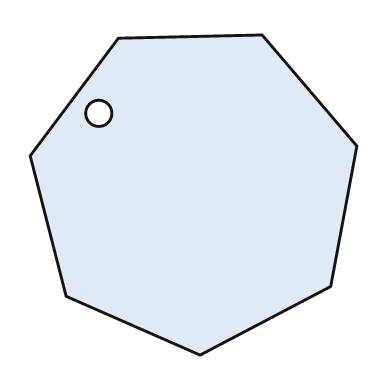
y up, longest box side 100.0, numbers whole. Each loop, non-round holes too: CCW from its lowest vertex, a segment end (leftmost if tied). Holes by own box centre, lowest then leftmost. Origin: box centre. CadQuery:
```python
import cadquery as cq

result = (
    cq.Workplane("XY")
    .moveTo(2.0, -49.0)
    .lineTo(42.0, -28.0)
    .lineTo(50.0, 15.0)
    .lineTo(21.0, 49.0)
    .lineTo(-23.0, 48.0)
    .lineTo(-50.0, 12.0)
    .lineTo(-39.0, -31.0)
    .close()
    .moveTo(-29.0, 25.0)
    .circle(4.0)
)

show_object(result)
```